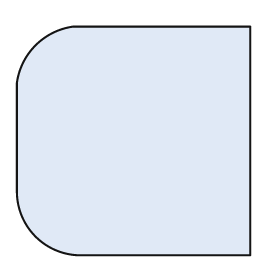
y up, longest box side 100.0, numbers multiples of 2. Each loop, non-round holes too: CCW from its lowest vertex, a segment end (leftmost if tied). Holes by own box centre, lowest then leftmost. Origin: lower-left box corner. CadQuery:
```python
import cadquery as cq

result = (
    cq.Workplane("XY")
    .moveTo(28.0, 0.0)
    .lineTo(100.0, 0.0)
    .lineTo(100.0, 98.0)
    .lineTo(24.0, 98.0)
    .threePointArc((8.0, 90.0), (0.0, 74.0))
    .lineTo(0.0, 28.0)
    .threePointArc((8.0, 8.0), (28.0, 0.0))
    .close()
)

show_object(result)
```